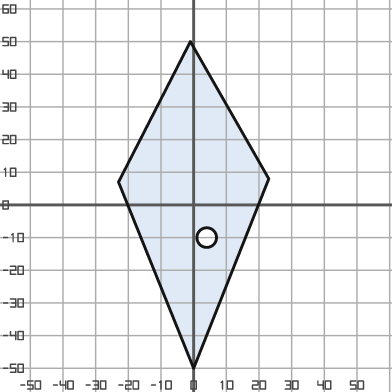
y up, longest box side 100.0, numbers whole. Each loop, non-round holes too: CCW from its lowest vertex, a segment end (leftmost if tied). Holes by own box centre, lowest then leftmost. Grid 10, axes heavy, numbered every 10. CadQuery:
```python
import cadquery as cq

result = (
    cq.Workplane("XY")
    .moveTo(0.0, -50.0)
    .lineTo(23.0, 8.0)
    .lineTo(-1.0, 50.0)
    .lineTo(-23.0, 7.0)
    .close()
    .moveTo(4.0, -10.0)
    .circle(3.0)
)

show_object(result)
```